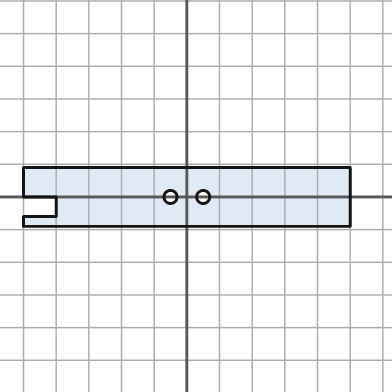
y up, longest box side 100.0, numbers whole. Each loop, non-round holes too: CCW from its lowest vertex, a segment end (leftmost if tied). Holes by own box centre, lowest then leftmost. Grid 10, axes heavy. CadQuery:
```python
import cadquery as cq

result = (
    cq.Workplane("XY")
    .moveTo(-50.0, -9.0)
    .lineTo(50.0, -9.0)
    .lineTo(50.0, 9.0)
    .lineTo(-50.0, 9.0)
    .lineTo(-50.0, 0.0)
    .lineTo(-40.0, 0.0)
    .lineTo(-40.0, -6.0)
    .lineTo(-50.0, -6.0)
    .close()
    .moveTo(-5.0, 0.0)
    .circle(2.0)
    .moveTo(5.0, 0.0)
    .circle(2.0)
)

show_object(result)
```